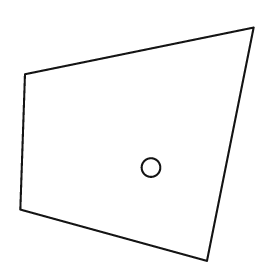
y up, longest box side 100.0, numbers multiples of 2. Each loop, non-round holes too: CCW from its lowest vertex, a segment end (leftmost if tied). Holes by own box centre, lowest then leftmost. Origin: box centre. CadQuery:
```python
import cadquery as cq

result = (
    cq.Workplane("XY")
    .moveTo(30.0, -50.0)
    .lineTo(50.0, 50.0)
    .lineTo(-48.0, 30.0)
    .lineTo(-50.0, -28.0)
    .close()
    .moveTo(6.0, -10.0)
    .circle(4.0)
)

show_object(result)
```